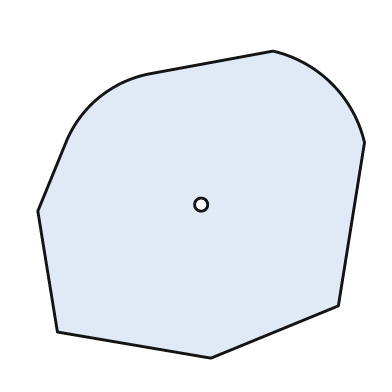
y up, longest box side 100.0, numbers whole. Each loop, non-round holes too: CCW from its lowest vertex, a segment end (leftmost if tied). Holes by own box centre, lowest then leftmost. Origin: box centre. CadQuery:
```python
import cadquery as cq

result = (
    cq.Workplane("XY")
    .moveTo(3.0, -47.0)
    .lineTo(42.0, -31.0)
    .lineTo(50.0, 19.0)
    .threePointArc((40.0, 37.0), (22.0, 47.0))
    .lineTo(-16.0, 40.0)
    .threePointArc((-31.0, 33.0), (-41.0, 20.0))
    .lineTo(-50.0, -2.0)
    .lineTo(-44.0, -39.0)
    .close()
    .moveTo(0.0, 0.0)
    .circle(2.0)
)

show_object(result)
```